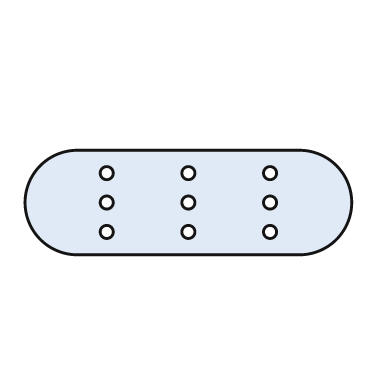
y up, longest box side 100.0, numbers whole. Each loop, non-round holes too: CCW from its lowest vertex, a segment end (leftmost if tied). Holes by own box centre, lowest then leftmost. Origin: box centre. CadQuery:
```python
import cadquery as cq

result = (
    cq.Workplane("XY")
    .moveTo(-34.0, -16.0)
    .lineTo(34.0, -16.0)
    .threePointArc((50.0, 0.0), (34.0, 16.0))
    .lineTo(-34.0, 16.0)
    .threePointArc((-50.0, 0.0), (-34.0, -16.0))
    .close()
    .moveTo(-25.0, -9.0)
    .circle(2.0)
    .moveTo(0.0, -9.0)
    .circle(2.0)
    .moveTo(25.0, -9.0)
    .circle(2.0)
    .moveTo(-25.0, 0.0)
    .circle(2.0)
    .moveTo(0.0, 0.0)
    .circle(2.0)
    .moveTo(25.0, 0.0)
    .circle(2.0)
    .moveTo(-25.0, 9.0)
    .circle(2.0)
    .moveTo(0.0, 9.0)
    .circle(2.0)
    .moveTo(25.0, 9.0)
    .circle(2.0)
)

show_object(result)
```